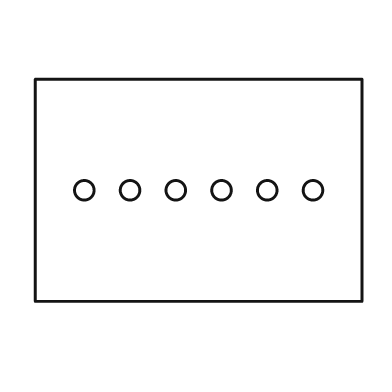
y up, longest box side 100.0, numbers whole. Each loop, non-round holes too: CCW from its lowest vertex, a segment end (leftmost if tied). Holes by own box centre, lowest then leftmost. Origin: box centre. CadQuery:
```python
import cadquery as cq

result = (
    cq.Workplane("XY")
    .moveTo(-50.0, -34.0)
    .lineTo(50.0, -34.0)
    .lineTo(50.0, 34.0)
    .lineTo(-50.0, 34.0)
    .close()
    .moveTo(-35.0, 0.0)
    .circle(3.0)
    .moveTo(-21.0, 0.0)
    .circle(3.0)
    .moveTo(-7.0, 0.0)
    .circle(3.0)
    .moveTo(7.0, 0.0)
    .circle(3.0)
    .moveTo(21.0, 0.0)
    .circle(3.0)
    .moveTo(35.0, 0.0)
    .circle(3.0)
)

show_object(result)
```